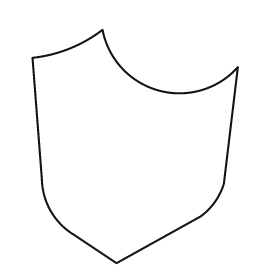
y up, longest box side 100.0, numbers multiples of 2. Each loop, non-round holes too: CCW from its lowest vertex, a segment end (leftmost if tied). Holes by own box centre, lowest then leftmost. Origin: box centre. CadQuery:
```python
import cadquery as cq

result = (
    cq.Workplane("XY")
    .moveTo(-8.0, -50.0)
    .lineTo(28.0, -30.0)
    .threePointArc((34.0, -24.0), (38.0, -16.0))
    .lineTo(44.0, 34.0)
    .threePointArc((10.0, 24.0), (-14.0, 50.0))
    .threePointArc((-28.0, 42.0), (-44.0, 38.0))
    .lineTo(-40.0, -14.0)
    .threePointArc((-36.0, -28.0), (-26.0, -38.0))
    .close()
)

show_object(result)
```